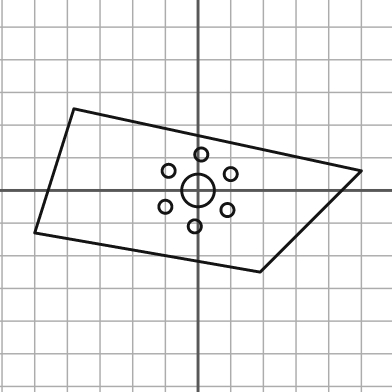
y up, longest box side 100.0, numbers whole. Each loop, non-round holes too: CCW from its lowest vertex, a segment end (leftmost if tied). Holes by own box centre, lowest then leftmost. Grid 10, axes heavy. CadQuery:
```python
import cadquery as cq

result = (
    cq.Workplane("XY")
    .moveTo(19.0, -25.0)
    .lineTo(50.0, 6.0)
    .lineTo(-38.0, 25.0)
    .lineTo(-50.0, -13.0)
    .close()
    .moveTo(-1.0, -11.0)
    .circle(2.0)
    .moveTo(9.0, -6.0)
    .circle(2.0)
    .moveTo(-10.0, -5.0)
    .circle(2.0)
    .moveTo(0.0, 0.0)
    .circle(5.0)
    .moveTo(10.0, 5.0)
    .circle(2.0)
    .moveTo(-9.0, 6.0)
    .circle(2.0)
    .moveTo(1.0, 11.0)
    .circle(2.0)
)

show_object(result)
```